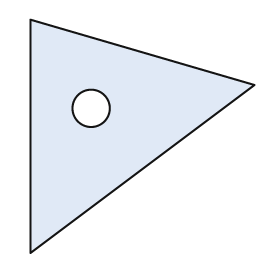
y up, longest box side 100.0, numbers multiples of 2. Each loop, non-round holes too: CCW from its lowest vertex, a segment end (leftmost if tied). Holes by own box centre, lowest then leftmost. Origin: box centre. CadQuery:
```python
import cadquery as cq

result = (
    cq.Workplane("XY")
    .moveTo(-48.0, -50.0)
    .lineTo(48.0, 22.0)
    .lineTo(-48.0, 50.0)
    .close()
    .moveTo(-22.0, 12.0)
    .circle(8.0)
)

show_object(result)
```